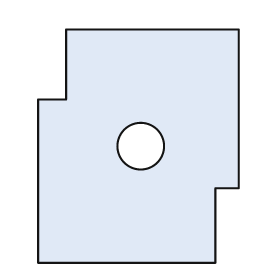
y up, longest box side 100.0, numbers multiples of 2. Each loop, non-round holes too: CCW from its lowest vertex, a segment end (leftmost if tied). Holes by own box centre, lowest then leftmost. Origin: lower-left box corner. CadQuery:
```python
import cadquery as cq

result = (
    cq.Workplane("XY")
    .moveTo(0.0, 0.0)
    .lineTo(76.0, 0.0)
    .lineTo(76.0, 32.0)
    .lineTo(86.0, 32.0)
    .lineTo(86.0, 100.0)
    .lineTo(12.0, 100.0)
    .lineTo(12.0, 70.0)
    .lineTo(0.0, 70.0)
    .close()
    .moveTo(44.0, 50.0)
    .circle(10.0)
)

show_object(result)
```